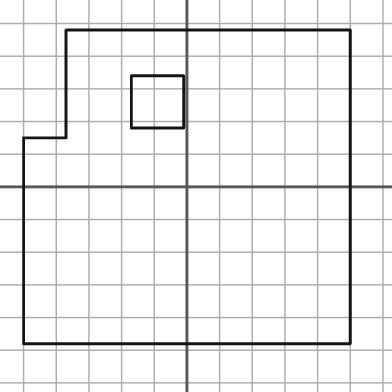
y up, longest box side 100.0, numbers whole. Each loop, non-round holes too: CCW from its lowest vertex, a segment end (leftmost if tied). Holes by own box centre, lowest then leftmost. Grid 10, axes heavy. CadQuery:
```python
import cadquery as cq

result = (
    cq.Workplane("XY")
    .moveTo(-50.0, -48.0)
    .lineTo(50.0, -48.0)
    .lineTo(50.0, 48.0)
    .lineTo(-37.0, 48.0)
    .lineTo(-37.0, 15.0)
    .lineTo(-50.0, 15.0)
    .close()
    .moveTo(-17.0, 18.0)
    .lineTo(-1.0, 18.0)
    .lineTo(-1.0, 34.0)
    .lineTo(-17.0, 34.0)
    .close()
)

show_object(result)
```